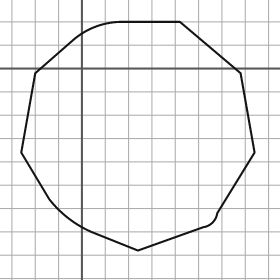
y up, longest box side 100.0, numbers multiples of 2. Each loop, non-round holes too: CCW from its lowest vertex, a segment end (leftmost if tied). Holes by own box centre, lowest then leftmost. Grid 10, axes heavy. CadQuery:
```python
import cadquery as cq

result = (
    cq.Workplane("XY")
    .moveTo(24.0, -78.0)
    .lineTo(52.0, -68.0)
    .threePointArc((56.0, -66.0), (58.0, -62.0))
    .lineTo(74.0, -36.0)
    .lineTo(68.0, -2.0)
    .lineTo(42.0, 20.0)
    .lineTo(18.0, 20.0)
    .threePointArc((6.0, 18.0), (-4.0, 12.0))
    .lineTo(-20.0, -2.0)
    .lineTo(-26.0, -36.0)
    .lineTo(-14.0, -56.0)
    .threePointArc((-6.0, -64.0), (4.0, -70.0))
    .close()
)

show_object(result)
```